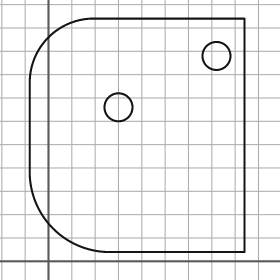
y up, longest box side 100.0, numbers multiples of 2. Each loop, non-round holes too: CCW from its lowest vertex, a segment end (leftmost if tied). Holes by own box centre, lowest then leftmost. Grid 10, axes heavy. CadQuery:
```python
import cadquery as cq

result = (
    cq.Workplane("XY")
    .moveTo(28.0, 4.0)
    .lineTo(84.0, 4.0)
    .lineTo(84.0, 104.0)
    .lineTo(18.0, 104.0)
    .threePointArc((0.0, 96.0), (-8.0, 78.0))
    .lineTo(-8.0, 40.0)
    .threePointArc((2.0, 14.0), (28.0, 4.0))
    .close()
    .moveTo(30.0, 66.0)
    .circle(6.0)
    .moveTo(72.0, 88.0)
    .circle(6.0)
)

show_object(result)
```